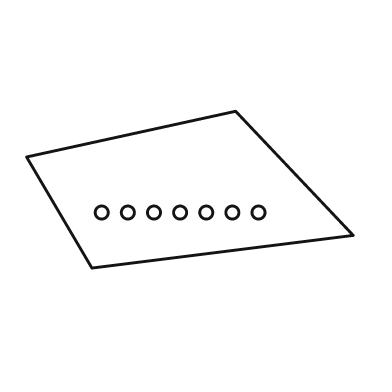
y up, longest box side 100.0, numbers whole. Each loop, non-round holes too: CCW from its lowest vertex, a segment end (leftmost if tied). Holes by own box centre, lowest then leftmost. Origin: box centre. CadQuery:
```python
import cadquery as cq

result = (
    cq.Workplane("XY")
    .moveTo(-30.0, -24.0)
    .lineTo(50.0, -14.0)
    .lineTo(14.0, 24.0)
    .lineTo(-50.0, 10.0)
    .close()
    .moveTo(-27.0, -7.0)
    .circle(2.0)
    .moveTo(-19.0, -7.0)
    .circle(2.0)
    .moveTo(-11.0, -7.0)
    .circle(2.0)
    .moveTo(-3.0, -7.0)
    .circle(2.0)
    .moveTo(5.0, -7.0)
    .circle(2.0)
    .moveTo(13.0, -7.0)
    .circle(2.0)
    .moveTo(21.0, -7.0)
    .circle(2.0)
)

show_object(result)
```